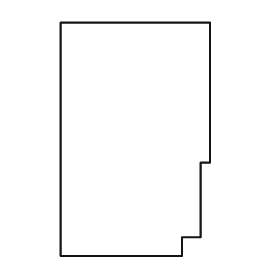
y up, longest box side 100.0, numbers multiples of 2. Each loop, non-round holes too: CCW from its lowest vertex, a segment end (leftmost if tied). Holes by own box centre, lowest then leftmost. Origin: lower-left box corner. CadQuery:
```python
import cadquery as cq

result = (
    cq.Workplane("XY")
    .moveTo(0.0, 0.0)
    .lineTo(52.0, 0.0)
    .lineTo(52.0, 8.0)
    .lineTo(60.0, 8.0)
    .lineTo(60.0, 40.0)
    .lineTo(64.0, 40.0)
    .lineTo(64.0, 100.0)
    .lineTo(0.0, 100.0)
    .close()
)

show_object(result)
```